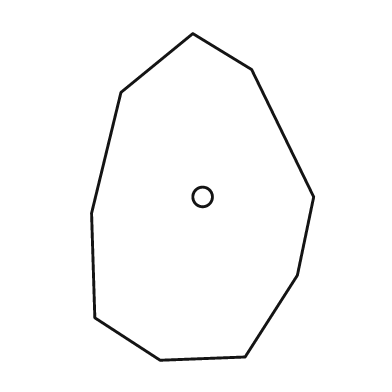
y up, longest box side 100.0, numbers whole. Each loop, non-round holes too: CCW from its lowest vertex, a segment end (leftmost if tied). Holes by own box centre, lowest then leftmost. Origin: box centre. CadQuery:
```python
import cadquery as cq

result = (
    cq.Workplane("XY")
    .moveTo(-13.0, -50.0)
    .lineTo(13.0, -49.0)
    .lineTo(29.0, -24.0)
    .lineTo(34.0, 0.0)
    .lineTo(15.0, 39.0)
    .lineTo(-3.0, 50.0)
    .lineTo(-25.0, 32.0)
    .lineTo(-34.0, -5.0)
    .lineTo(-33.0, -37.0)
    .close()
    .moveTo(0.0, 0.0)
    .circle(3.0)
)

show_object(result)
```